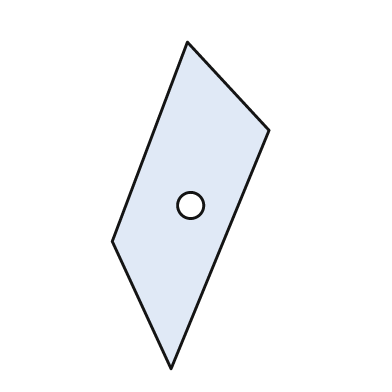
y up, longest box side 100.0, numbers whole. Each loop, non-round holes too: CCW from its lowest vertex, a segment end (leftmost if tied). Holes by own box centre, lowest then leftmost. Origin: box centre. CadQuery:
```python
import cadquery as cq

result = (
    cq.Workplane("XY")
    .moveTo(-6.0, -50.0)
    .lineTo(24.0, 23.0)
    .lineTo(-1.0, 50.0)
    .lineTo(-24.0, -11.0)
    .close()
    .moveTo(0.0, 0.0)
    .circle(4.0)
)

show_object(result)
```